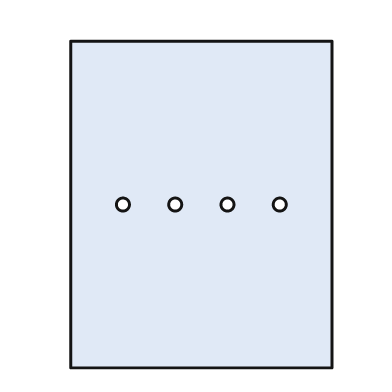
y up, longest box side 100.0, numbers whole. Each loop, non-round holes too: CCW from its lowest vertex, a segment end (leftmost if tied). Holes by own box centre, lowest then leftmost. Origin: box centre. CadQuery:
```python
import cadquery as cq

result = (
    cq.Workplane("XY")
    .moveTo(-40.0, -50.0)
    .lineTo(40.0, -50.0)
    .lineTo(40.0, 50.0)
    .lineTo(-40.0, 50.0)
    .close()
    .moveTo(-24.0, 0.0)
    .circle(2.0)
    .moveTo(-8.0, 0.0)
    .circle(2.0)
    .moveTo(8.0, 0.0)
    .circle(2.0)
    .moveTo(24.0, 0.0)
    .circle(2.0)
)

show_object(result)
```